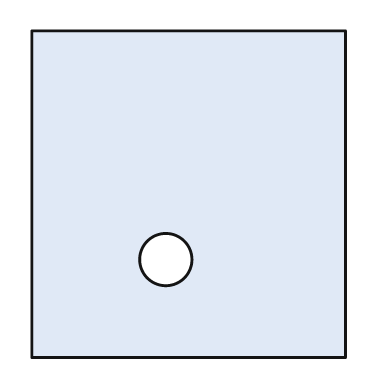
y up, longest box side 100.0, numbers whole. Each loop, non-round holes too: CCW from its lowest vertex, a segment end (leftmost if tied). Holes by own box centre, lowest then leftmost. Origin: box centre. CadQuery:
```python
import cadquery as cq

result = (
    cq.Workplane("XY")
    .moveTo(-48.0, -50.0)
    .lineTo(48.0, -50.0)
    .lineTo(48.0, 50.0)
    .lineTo(-48.0, 50.0)
    .close()
    .moveTo(-7.0, -20.0)
    .circle(8.0)
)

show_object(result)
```